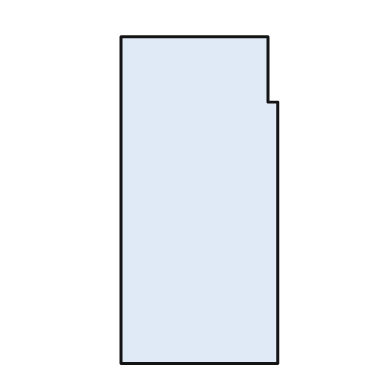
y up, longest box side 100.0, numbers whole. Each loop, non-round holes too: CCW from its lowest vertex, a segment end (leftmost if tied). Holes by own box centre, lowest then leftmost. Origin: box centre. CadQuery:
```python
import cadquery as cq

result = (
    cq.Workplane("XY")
    .moveTo(-24.0, -50.0)
    .lineTo(24.0, -50.0)
    .lineTo(24.0, 30.0)
    .lineTo(21.0, 30.0)
    .lineTo(21.0, 50.0)
    .lineTo(-24.0, 50.0)
    .close()
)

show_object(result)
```